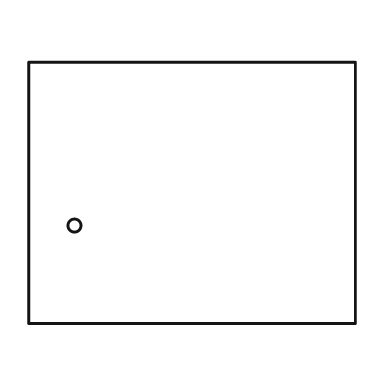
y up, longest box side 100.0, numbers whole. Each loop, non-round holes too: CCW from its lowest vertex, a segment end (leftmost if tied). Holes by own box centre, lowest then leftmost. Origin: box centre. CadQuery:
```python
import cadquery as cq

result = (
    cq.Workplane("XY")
    .moveTo(-50.0, -40.0)
    .lineTo(50.0, -40.0)
    .lineTo(50.0, 40.0)
    .lineTo(-50.0, 40.0)
    .close()
    .moveTo(-36.0, -10.0)
    .circle(2.0)
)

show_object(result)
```